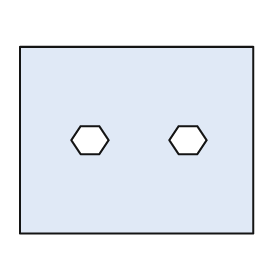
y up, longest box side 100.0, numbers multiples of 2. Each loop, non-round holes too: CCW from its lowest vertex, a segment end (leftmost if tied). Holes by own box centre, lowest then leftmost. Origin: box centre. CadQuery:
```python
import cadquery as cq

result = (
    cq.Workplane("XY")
    .moveTo(-50.0, -40.0)
    .lineTo(50.0, -40.0)
    .lineTo(50.0, 40.0)
    .lineTo(-50.0, 40.0)
    .close()
    .moveTo(-24.0, -6.0)
    .lineTo(-16.0, -6.0)
    .lineTo(-12.0, 0.0)
    .lineTo(-16.0, 6.0)
    .lineTo(-24.0, 6.0)
    .lineTo(-28.0, 0.0)
    .close()
    .moveTo(18.0, -6.0)
    .lineTo(26.0, -6.0)
    .lineTo(30.0, 0.0)
    .lineTo(26.0, 6.0)
    .lineTo(18.0, 6.0)
    .lineTo(14.0, 0.0)
    .close()
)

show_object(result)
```